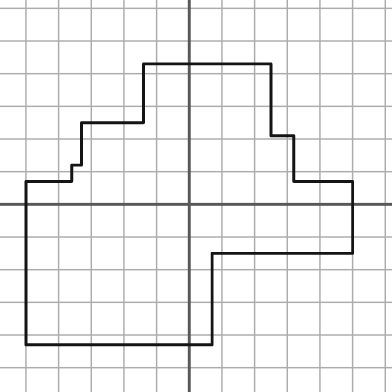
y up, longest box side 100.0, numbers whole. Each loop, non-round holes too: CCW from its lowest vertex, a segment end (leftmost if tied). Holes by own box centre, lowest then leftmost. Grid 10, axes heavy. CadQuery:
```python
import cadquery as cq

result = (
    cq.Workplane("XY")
    .moveTo(-50.0, -43.0)
    .lineTo(7.0, -43.0)
    .lineTo(7.0, -15.0)
    .lineTo(50.0, -15.0)
    .lineTo(50.0, 7.0)
    .lineTo(32.0, 7.0)
    .lineTo(32.0, 21.0)
    .lineTo(25.0, 21.0)
    .lineTo(25.0, 43.0)
    .lineTo(-14.0, 43.0)
    .lineTo(-14.0, 25.0)
    .lineTo(-33.0, 25.0)
    .lineTo(-33.0, 12.0)
    .lineTo(-36.0, 12.0)
    .lineTo(-36.0, 7.0)
    .lineTo(-50.0, 7.0)
    .close()
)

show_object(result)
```